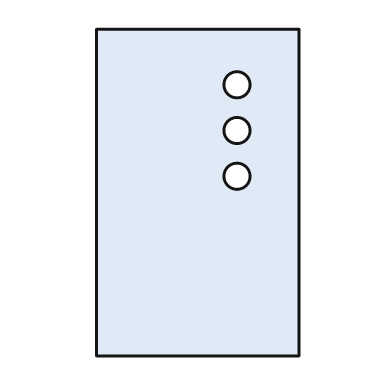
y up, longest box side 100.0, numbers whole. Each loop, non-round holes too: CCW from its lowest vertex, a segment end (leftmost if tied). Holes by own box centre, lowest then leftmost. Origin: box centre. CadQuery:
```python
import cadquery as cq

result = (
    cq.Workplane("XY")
    .moveTo(-31.0, -50.0)
    .lineTo(31.0, -50.0)
    .lineTo(31.0, 50.0)
    .lineTo(-31.0, 50.0)
    .close()
    .moveTo(12.0, 5.0)
    .circle(4.0)
    .moveTo(12.0, 19.0)
    .circle(4.0)
    .moveTo(12.0, 33.0)
    .circle(4.0)
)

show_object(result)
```